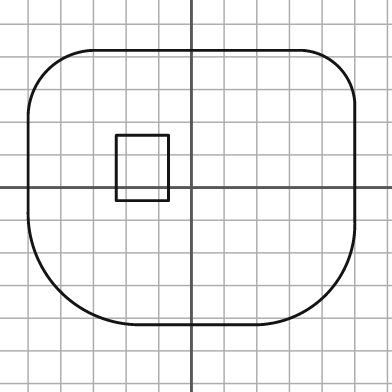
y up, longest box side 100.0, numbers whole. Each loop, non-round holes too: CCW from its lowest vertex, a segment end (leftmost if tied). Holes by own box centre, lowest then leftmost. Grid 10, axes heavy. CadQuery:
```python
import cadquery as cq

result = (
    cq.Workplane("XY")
    .moveTo(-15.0, -42.0)
    .lineTo(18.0, -42.0)
    .threePointArc((41.0, -33.0), (50.0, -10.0))
    .lineTo(50.0, 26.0)
    .threePointArc((45.0, 37.0), (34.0, 42.0))
    .lineTo(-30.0, 42.0)
    .threePointArc((-44.0, 36.0), (-50.0, 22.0))
    .lineTo(-50.0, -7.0)
    .threePointArc((-40.0, -32.0), (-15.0, -42.0))
    .close()
    .moveTo(-23.0, -4.0)
    .lineTo(-7.0, -4.0)
    .lineTo(-7.0, 16.0)
    .lineTo(-23.0, 16.0)
    .close()
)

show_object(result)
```